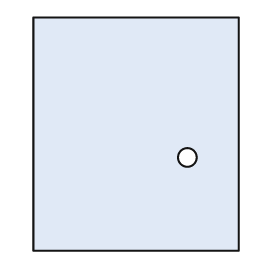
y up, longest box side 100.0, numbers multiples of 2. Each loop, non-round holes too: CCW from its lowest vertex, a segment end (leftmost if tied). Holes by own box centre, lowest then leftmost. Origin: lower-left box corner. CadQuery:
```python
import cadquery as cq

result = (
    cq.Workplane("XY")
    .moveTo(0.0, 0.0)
    .lineTo(88.0, 0.0)
    .lineTo(88.0, 100.0)
    .lineTo(0.0, 100.0)
    .close()
    .moveTo(66.0, 40.0)
    .circle(4.0)
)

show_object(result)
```